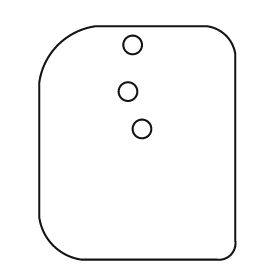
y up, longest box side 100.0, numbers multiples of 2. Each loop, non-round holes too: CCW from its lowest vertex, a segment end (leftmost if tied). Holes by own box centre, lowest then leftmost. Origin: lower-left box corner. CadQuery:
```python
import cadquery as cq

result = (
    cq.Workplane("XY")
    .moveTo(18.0, 0.0)
    .lineTo(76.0, 0.0)
    .threePointArc((82.0, 2.0), (84.0, 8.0))
    .lineTo(84.0, 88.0)
    .threePointArc((80.0, 96.0), (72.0, 100.0))
    .lineTo(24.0, 100.0)
    .threePointArc((8.0, 92.0), (0.0, 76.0))
    .lineTo(0.0, 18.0)
    .threePointArc((6.0, 6.0), (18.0, 0.0))
    .close()
    .moveTo(44.0, 56.0)
    .circle(4.0)
    .moveTo(38.0, 72.0)
    .circle(4.0)
    .moveTo(40.0, 92.0)
    .circle(4.0)
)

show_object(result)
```